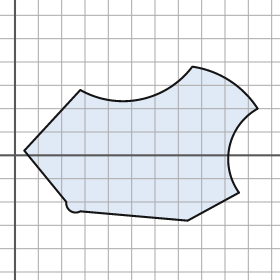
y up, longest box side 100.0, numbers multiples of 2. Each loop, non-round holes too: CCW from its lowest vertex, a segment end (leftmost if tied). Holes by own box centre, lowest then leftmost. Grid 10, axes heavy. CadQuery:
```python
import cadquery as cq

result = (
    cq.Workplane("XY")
    .moveTo(74.0, -28.0)
    .lineTo(96.0, -16.0)
    .threePointArc((92.0, 4.0), (104.0, 20.0))
    .threePointArc((92.0, 32.0), (76.0, 38.0))
    .threePointArc((54.0, 24.0), (28.0, 28.0))
    .lineTo(4.0, 2.0)
    .lineTo(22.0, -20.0)
    .threePointArc((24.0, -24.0), (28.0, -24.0))
    .close()
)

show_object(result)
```